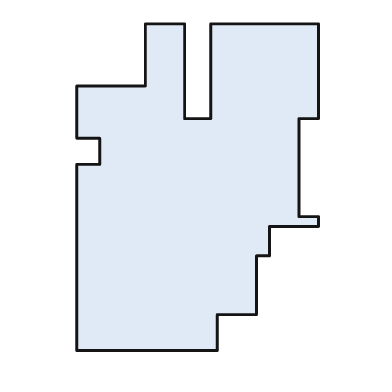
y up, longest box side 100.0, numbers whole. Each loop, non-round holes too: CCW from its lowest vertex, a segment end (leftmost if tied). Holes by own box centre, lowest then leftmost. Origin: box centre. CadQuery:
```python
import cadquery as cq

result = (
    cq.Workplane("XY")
    .moveTo(-37.0, -50.0)
    .lineTo(6.0, -50.0)
    .lineTo(6.0, -39.0)
    .lineTo(18.0, -39.0)
    .lineTo(18.0, -21.0)
    .lineTo(22.0, -21.0)
    .lineTo(22.0, -12.0)
    .lineTo(37.0, -12.0)
    .lineTo(37.0, -9.0)
    .lineTo(31.0, -9.0)
    .lineTo(31.0, 21.0)
    .lineTo(37.0, 21.0)
    .lineTo(37.0, 50.0)
    .lineTo(4.0, 50.0)
    .lineTo(4.0, 21.0)
    .lineTo(-4.0, 21.0)
    .lineTo(-4.0, 50.0)
    .lineTo(-16.0, 50.0)
    .lineTo(-16.0, 31.0)
    .lineTo(-37.0, 31.0)
    .lineTo(-37.0, 15.0)
    .lineTo(-30.0, 15.0)
    .lineTo(-30.0, 7.0)
    .lineTo(-37.0, 7.0)
    .close()
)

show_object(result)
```